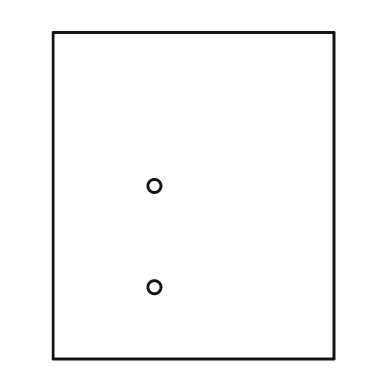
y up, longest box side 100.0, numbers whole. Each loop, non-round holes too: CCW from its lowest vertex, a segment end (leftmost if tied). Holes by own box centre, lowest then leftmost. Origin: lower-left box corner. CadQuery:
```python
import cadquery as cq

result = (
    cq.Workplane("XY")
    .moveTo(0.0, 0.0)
    .lineTo(86.0, 0.0)
    .lineTo(86.0, 100.0)
    .lineTo(0.0, 100.0)
    .close()
    .moveTo(31.0, 22.0)
    .circle(2.0)
    .moveTo(31.0, 53.0)
    .circle(2.0)
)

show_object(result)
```